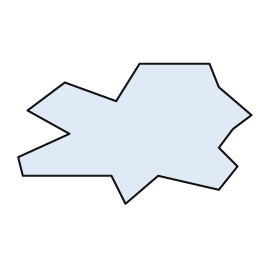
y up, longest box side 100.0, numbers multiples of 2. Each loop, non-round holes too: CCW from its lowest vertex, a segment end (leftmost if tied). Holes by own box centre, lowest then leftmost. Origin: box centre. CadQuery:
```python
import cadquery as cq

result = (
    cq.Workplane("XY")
    .moveTo(-4.0, -30.0)
    .lineTo(10.0, -18.0)
    .lineTo(36.0, -24.0)
    .lineTo(44.0, -14.0)
    .lineTo(36.0, -6.0)
    .lineTo(42.0, 2.0)
    .lineTo(50.0, 8.0)
    .lineTo(36.0, 20.0)
    .lineTo(32.0, 30.0)
    .lineTo(2.0, 30.0)
    .lineTo(-8.0, 14.0)
    .lineTo(-30.0, 22.0)
    .lineTo(-46.0, 10.0)
    .lineTo(-28.0, 0.0)
    .lineTo(-50.0, -10.0)
    .lineTo(-48.0, -18.0)
    .lineTo(-10.0, -18.0)
    .close()
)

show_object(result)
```